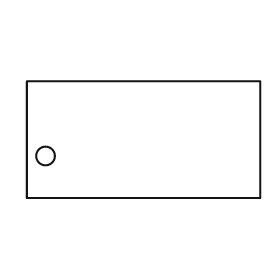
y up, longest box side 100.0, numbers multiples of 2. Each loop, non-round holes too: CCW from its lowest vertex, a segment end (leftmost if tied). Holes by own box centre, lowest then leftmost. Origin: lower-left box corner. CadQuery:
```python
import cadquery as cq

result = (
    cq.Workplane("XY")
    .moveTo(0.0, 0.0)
    .lineTo(100.0, 0.0)
    .lineTo(100.0, 50.0)
    .lineTo(0.0, 50.0)
    .close()
    .moveTo(8.0, 18.0)
    .circle(4.0)
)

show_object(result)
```